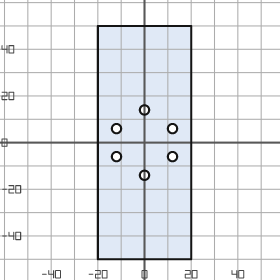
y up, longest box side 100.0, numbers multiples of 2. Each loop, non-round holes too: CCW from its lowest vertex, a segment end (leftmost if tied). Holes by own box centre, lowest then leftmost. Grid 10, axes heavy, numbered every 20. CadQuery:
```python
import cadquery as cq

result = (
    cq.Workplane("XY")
    .moveTo(-20.0, -50.0)
    .lineTo(20.0, -50.0)
    .lineTo(20.0, 50.0)
    .lineTo(-20.0, 50.0)
    .close()
    .moveTo(0.0, -14.0)
    .circle(2.0)
    .moveTo(-12.0, -6.0)
    .circle(2.0)
    .moveTo(12.0, -6.0)
    .circle(2.0)
    .moveTo(-12.0, 6.0)
    .circle(2.0)
    .moveTo(12.0, 6.0)
    .circle(2.0)
    .moveTo(0.0, 14.0)
    .circle(2.0)
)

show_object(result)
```